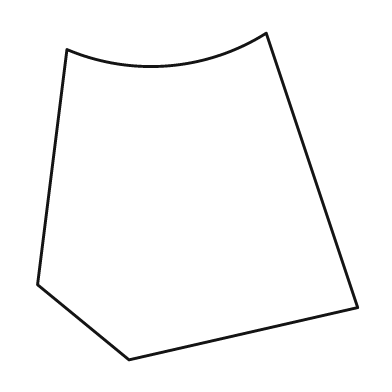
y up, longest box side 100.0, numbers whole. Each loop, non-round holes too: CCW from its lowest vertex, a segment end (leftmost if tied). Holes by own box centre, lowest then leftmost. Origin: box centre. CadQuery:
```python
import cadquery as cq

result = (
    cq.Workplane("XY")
    .moveTo(-21.0, -50.0)
    .lineTo(49.0, -34.0)
    .lineTo(21.0, 50.0)
    .threePointArc((-9.0, 40.0), (-40.0, 45.0))
    .lineTo(-49.0, -27.0)
    .close()
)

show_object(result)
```